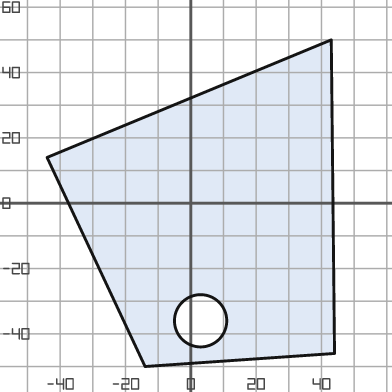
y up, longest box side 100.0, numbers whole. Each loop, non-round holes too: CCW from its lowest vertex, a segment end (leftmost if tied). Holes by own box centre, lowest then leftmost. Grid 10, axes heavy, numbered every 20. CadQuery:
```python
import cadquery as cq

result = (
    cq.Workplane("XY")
    .moveTo(-14.0, -50.0)
    .lineTo(44.0, -46.0)
    .lineTo(43.0, 50.0)
    .lineTo(-44.0, 14.0)
    .close()
    .moveTo(3.0, -36.0)
    .circle(8.0)
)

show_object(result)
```